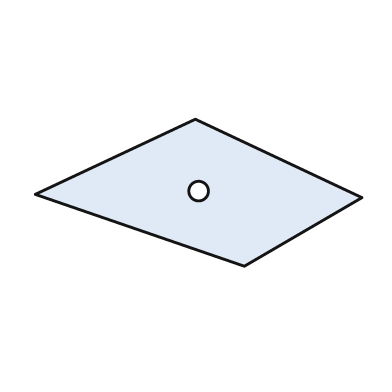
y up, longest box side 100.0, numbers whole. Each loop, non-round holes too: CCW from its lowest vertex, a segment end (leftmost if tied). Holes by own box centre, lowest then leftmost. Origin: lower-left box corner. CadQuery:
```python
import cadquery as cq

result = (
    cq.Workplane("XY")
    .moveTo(64.0, 0.0)
    .lineTo(100.0, 21.0)
    .lineTo(49.0, 45.0)
    .lineTo(0.0, 22.0)
    .close()
    .moveTo(50.0, 23.0)
    .circle(3.0)
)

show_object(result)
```